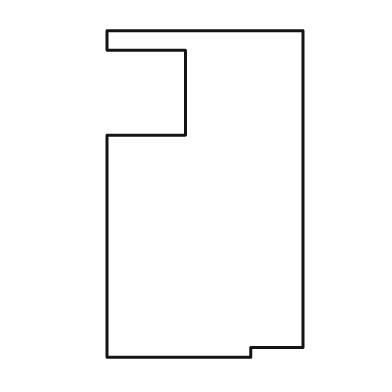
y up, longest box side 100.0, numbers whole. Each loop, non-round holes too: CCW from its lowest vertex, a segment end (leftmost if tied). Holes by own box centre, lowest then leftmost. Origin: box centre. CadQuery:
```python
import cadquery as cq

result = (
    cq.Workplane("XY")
    .moveTo(-30.0, -50.0)
    .lineTo(14.0, -50.0)
    .lineTo(14.0, -47.0)
    .lineTo(30.0, -47.0)
    .lineTo(30.0, 50.0)
    .lineTo(-30.0, 50.0)
    .lineTo(-30.0, 44.0)
    .lineTo(-6.0, 44.0)
    .lineTo(-6.0, 18.0)
    .lineTo(-30.0, 18.0)
    .close()
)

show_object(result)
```